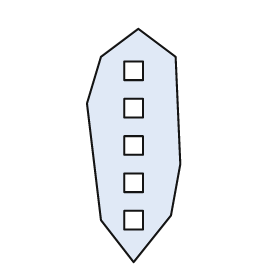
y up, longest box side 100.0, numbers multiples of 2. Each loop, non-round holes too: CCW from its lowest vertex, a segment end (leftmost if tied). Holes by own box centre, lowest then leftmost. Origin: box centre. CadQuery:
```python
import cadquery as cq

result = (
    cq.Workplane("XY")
    .moveTo(0.0, -50.0)
    .lineTo(16.0, -30.0)
    .lineTo(20.0, -8.0)
    .lineTo(18.0, 38.0)
    .lineTo(2.0, 50.0)
    .lineTo(-14.0, 38.0)
    .lineTo(-20.0, 18.0)
    .lineTo(-14.0, -32.0)
    .close()
    .moveTo(-4.0, -36.0)
    .lineTo(4.0, -36.0)
    .lineTo(4.0, -28.0)
    .lineTo(-4.0, -28.0)
    .close()
    .moveTo(-4.0, -20.0)
    .lineTo(4.0, -20.0)
    .lineTo(4.0, -12.0)
    .lineTo(-4.0, -12.0)
    .close()
    .moveTo(-4.0, -4.0)
    .lineTo(4.0, -4.0)
    .lineTo(4.0, 4.0)
    .lineTo(-4.0, 4.0)
    .close()
    .moveTo(-4.0, 12.0)
    .lineTo(4.0, 12.0)
    .lineTo(4.0, 20.0)
    .lineTo(-4.0, 20.0)
    .close()
    .moveTo(-4.0, 28.0)
    .lineTo(4.0, 28.0)
    .lineTo(4.0, 36.0)
    .lineTo(-4.0, 36.0)
    .close()
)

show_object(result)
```